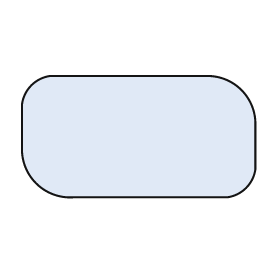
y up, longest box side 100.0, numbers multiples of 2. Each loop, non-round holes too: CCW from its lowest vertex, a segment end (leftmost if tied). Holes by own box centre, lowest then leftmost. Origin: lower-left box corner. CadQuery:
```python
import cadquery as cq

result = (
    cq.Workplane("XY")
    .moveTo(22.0, 0.0)
    .lineTo(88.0, 0.0)
    .threePointArc((96.0, 4.0), (100.0, 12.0))
    .lineTo(100.0, 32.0)
    .threePointArc((94.0, 46.0), (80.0, 52.0))
    .lineTo(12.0, 52.0)
    .threePointArc((4.0, 48.0), (0.0, 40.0))
    .lineTo(0.0, 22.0)
    .threePointArc((6.0, 6.0), (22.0, 0.0))
    .close()
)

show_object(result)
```